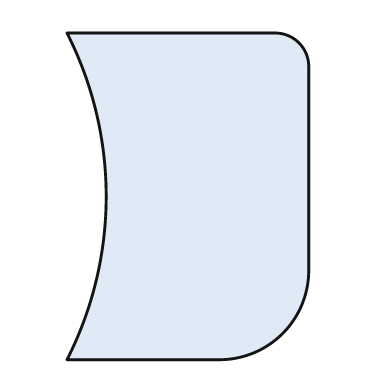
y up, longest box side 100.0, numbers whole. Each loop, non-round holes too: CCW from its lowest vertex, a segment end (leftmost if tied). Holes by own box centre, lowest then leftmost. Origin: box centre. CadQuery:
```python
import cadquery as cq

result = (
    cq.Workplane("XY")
    .moveTo(-37.0, -50.0)
    .lineTo(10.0, -50.0)
    .threePointArc((29.0, -42.0), (37.0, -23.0))
    .lineTo(37.0, 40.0)
    .threePointArc((34.0, 47.0), (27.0, 50.0))
    .lineTo(-37.0, 50.0)
    .threePointArc((-25.0, 0.0), (-37.0, -50.0))
    .close()
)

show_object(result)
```